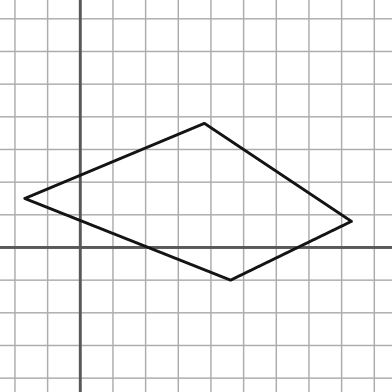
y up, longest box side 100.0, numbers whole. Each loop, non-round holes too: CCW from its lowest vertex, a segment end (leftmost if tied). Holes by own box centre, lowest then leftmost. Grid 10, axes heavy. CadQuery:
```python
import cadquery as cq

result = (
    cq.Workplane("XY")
    .moveTo(46.0, -10.0)
    .lineTo(83.0, 8.0)
    .lineTo(38.0, 38.0)
    .lineTo(-17.0, 15.0)
    .close()
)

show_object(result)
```